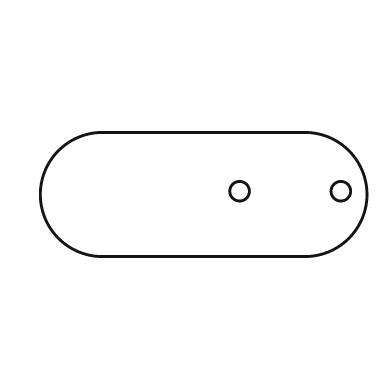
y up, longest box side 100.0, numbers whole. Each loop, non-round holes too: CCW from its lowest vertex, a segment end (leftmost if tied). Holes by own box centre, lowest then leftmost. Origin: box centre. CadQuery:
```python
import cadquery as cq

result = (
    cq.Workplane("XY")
    .moveTo(-31.0, -19.0)
    .lineTo(31.0, -19.0)
    .threePointArc((50.0, 0.0), (31.0, 19.0))
    .lineTo(-31.0, 19.0)
    .threePointArc((-50.0, 0.0), (-31.0, -19.0))
    .close()
    .moveTo(11.0, 1.0)
    .circle(3.0)
    .moveTo(42.0, 1.0)
    .circle(3.0)
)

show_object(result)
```